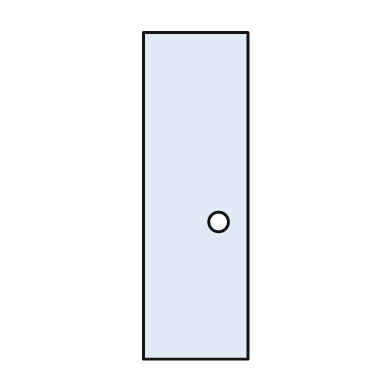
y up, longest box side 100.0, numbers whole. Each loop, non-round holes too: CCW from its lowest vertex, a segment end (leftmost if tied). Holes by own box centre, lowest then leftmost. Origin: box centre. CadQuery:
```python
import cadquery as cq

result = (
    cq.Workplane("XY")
    .moveTo(-16.0, -50.0)
    .lineTo(16.0, -50.0)
    .lineTo(16.0, 50.0)
    .lineTo(-16.0, 50.0)
    .close()
    .moveTo(7.0, -8.0)
    .circle(3.0)
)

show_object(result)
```